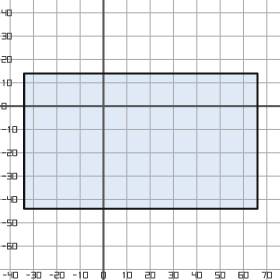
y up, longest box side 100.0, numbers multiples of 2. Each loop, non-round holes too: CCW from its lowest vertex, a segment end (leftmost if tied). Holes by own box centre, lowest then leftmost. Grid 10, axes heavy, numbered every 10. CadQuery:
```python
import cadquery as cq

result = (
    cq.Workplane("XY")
    .moveTo(-34.0, -44.0)
    .lineTo(66.0, -44.0)
    .lineTo(66.0, 14.0)
    .lineTo(-34.0, 14.0)
    .close()
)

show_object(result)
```